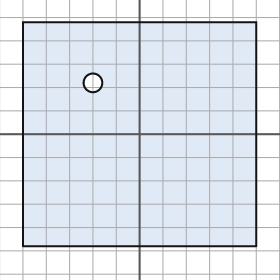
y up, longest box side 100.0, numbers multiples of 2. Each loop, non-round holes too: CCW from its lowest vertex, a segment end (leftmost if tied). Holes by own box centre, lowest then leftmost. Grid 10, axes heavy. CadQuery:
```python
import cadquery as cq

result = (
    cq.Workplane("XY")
    .moveTo(-50.0, -48.0)
    .lineTo(50.0, -48.0)
    .lineTo(50.0, 48.0)
    .lineTo(-50.0, 48.0)
    .close()
    .moveTo(-20.0, 22.0)
    .circle(4.0)
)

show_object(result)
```